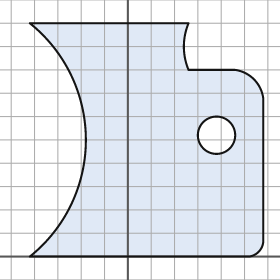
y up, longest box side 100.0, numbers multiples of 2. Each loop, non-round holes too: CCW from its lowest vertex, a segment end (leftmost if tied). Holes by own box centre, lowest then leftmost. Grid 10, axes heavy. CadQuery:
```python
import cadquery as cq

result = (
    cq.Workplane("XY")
    .moveTo(-42.0, 0.0)
    .lineTo(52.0, 0.0)
    .threePointArc((56.0, 2.0), (58.0, 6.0))
    .lineTo(58.0, 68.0)
    .threePointArc((54.0, 76.0), (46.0, 80.0))
    .lineTo(26.0, 80.0)
    .threePointArc((24.0, 90.0), (26.0, 100.0))
    .lineTo(-42.0, 100.0)
    .threePointArc((-18.0, 50.0), (-42.0, 0.0))
    .close()
    .moveTo(38.0, 52.0)
    .circle(8.0)
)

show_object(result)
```